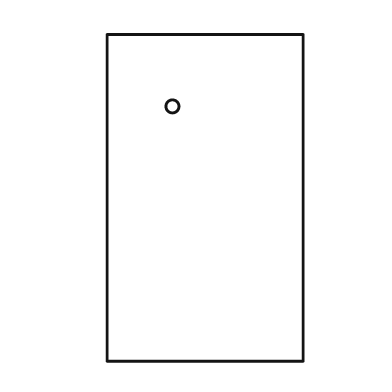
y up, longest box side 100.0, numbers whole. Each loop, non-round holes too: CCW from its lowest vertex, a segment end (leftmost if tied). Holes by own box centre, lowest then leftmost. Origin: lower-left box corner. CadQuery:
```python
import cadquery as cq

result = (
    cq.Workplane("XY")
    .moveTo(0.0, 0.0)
    .lineTo(60.0, 0.0)
    .lineTo(60.0, 100.0)
    .lineTo(0.0, 100.0)
    .close()
    .moveTo(20.0, 78.0)
    .circle(2.0)
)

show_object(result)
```